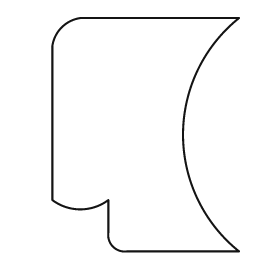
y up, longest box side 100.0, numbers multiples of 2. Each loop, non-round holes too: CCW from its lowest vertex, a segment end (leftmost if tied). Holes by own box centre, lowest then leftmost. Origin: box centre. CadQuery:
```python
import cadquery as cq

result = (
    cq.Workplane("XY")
    .moveTo(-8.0, -50.0)
    .lineTo(40.0, -50.0)
    .threePointArc((16.0, 0.0), (40.0, 50.0))
    .lineTo(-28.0, 50.0)
    .threePointArc((-36.0, 46.0), (-40.0, 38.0))
    .lineTo(-40.0, -28.0)
    .threePointArc((-28.0, -32.0), (-16.0, -28.0))
    .lineTo(-16.0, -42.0)
    .threePointArc((-14.0, -48.0), (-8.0, -50.0))
    .close()
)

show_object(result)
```